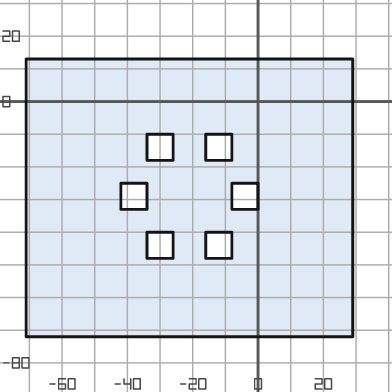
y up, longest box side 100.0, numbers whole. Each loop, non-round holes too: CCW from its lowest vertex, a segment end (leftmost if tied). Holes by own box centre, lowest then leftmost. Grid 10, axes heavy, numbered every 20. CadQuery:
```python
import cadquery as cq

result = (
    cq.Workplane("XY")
    .moveTo(-71.0, -72.0)
    .lineTo(29.0, -72.0)
    .lineTo(29.0, 13.0)
    .lineTo(-71.0, 13.0)
    .close()
    .moveTo(-34.0, -48.0)
    .lineTo(-26.0, -48.0)
    .lineTo(-26.0, -40.0)
    .lineTo(-34.0, -40.0)
    .close()
    .moveTo(-16.0, -48.0)
    .lineTo(-8.0, -48.0)
    .lineTo(-8.0, -40.0)
    .lineTo(-16.0, -40.0)
    .close()
    .moveTo(-42.0, -33.0)
    .lineTo(-34.0, -33.0)
    .lineTo(-34.0, -25.0)
    .lineTo(-42.0, -25.0)
    .close()
    .moveTo(-8.0, -33.0)
    .lineTo(0.0, -33.0)
    .lineTo(0.0, -25.0)
    .lineTo(-8.0, -25.0)
    .close()
    .moveTo(-34.0, -18.0)
    .lineTo(-26.0, -18.0)
    .lineTo(-26.0, -10.0)
    .lineTo(-34.0, -10.0)
    .close()
    .moveTo(-16.0, -18.0)
    .lineTo(-8.0, -18.0)
    .lineTo(-8.0, -10.0)
    .lineTo(-16.0, -10.0)
    .close()
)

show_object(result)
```